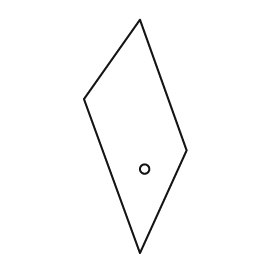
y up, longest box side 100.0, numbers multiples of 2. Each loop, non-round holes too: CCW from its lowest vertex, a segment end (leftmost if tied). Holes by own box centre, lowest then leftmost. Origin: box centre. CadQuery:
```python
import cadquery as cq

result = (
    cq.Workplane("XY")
    .moveTo(2.0, -50.0)
    .lineTo(22.0, -6.0)
    .lineTo(2.0, 50.0)
    .lineTo(-22.0, 16.0)
    .close()
    .moveTo(4.0, -14.0)
    .circle(2.0)
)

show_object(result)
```